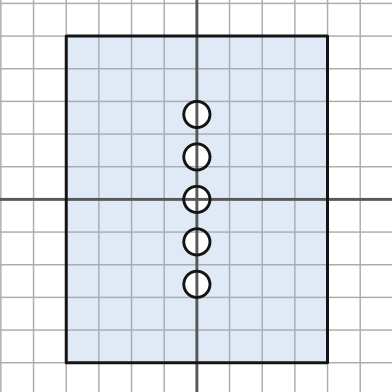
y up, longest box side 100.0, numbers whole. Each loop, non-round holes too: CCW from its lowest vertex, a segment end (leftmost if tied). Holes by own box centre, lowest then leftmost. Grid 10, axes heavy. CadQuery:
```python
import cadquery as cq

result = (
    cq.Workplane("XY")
    .moveTo(-40.0, -50.0)
    .lineTo(40.0, -50.0)
    .lineTo(40.0, 50.0)
    .lineTo(-40.0, 50.0)
    .close()
    .moveTo(0.0, -26.0)
    .circle(4.0)
    .moveTo(0.0, -13.0)
    .circle(4.0)
    .moveTo(0.0, 0.0)
    .circle(4.0)
    .moveTo(0.0, 13.0)
    .circle(4.0)
    .moveTo(0.0, 26.0)
    .circle(4.0)
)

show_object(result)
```